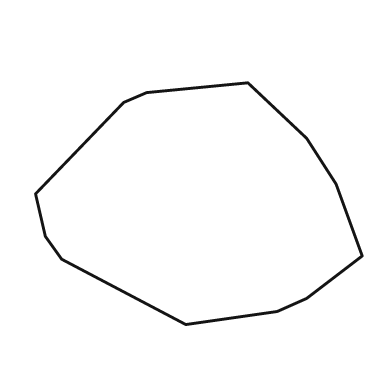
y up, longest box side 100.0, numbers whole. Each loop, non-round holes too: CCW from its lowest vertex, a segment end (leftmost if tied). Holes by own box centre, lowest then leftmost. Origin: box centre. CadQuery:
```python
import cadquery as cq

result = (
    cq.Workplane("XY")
    .moveTo(-4.0, -37.0)
    .lineTo(24.0, -33.0)
    .lineTo(33.0, -29.0)
    .lineTo(50.0, -16.0)
    .lineTo(42.0, 6.0)
    .lineTo(33.0, 20.0)
    .lineTo(15.0, 37.0)
    .lineTo(-16.0, 34.0)
    .lineTo(-23.0, 31.0)
    .lineTo(-50.0, 3.0)
    .lineTo(-47.0, -10.0)
    .lineTo(-42.0, -17.0)
    .close()
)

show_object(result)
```